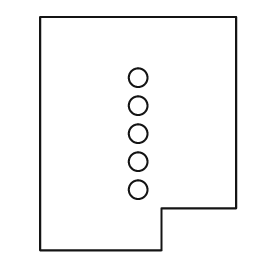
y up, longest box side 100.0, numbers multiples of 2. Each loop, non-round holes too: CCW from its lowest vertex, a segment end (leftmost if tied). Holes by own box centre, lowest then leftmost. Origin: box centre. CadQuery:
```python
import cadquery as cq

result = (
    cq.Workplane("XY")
    .moveTo(-42.0, -50.0)
    .lineTo(10.0, -50.0)
    .lineTo(10.0, -32.0)
    .lineTo(42.0, -32.0)
    .lineTo(42.0, 50.0)
    .lineTo(-42.0, 50.0)
    .close()
    .moveTo(0.0, -24.0)
    .circle(4.0)
    .moveTo(0.0, -12.0)
    .circle(4.0)
    .moveTo(0.0, 0.0)
    .circle(4.0)
    .moveTo(0.0, 12.0)
    .circle(4.0)
    .moveTo(0.0, 24.0)
    .circle(4.0)
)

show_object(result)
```